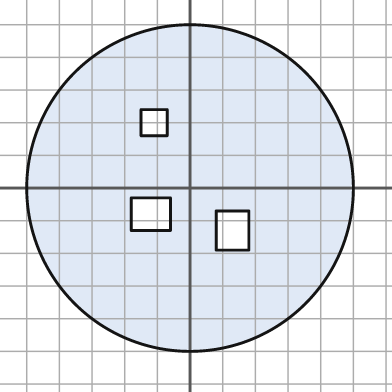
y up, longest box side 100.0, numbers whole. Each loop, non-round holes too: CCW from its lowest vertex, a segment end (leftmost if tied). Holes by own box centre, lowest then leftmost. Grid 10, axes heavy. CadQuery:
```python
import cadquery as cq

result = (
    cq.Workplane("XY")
    .moveTo(0.0, 0.0)
    .circle(50.0)
    .moveTo(8.0, -19.0)
    .lineTo(18.0, -19.0)
    .lineTo(18.0, -7.0)
    .lineTo(8.0, -7.0)
    .close()
    .moveTo(-18.0, -13.0)
    .lineTo(-6.0, -13.0)
    .lineTo(-6.0, -3.0)
    .lineTo(-18.0, -3.0)
    .close()
    .moveTo(-15.0, 16.0)
    .lineTo(-7.0, 16.0)
    .lineTo(-7.0, 24.0)
    .lineTo(-15.0, 24.0)
    .close()
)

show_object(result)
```